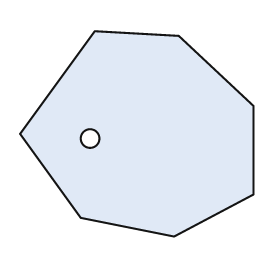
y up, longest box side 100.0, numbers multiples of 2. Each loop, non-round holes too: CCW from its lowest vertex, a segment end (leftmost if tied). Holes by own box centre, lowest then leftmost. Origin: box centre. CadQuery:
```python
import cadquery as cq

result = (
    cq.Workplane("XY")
    .moveTo(16.0, -44.0)
    .lineTo(50.0, -26.0)
    .lineTo(50.0, 12.0)
    .lineTo(18.0, 42.0)
    .lineTo(-18.0, 44.0)
    .lineTo(-50.0, 0.0)
    .lineTo(-24.0, -36.0)
    .close()
    .moveTo(-20.0, -2.0)
    .circle(4.0)
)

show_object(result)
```